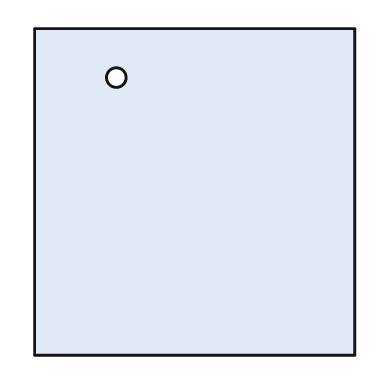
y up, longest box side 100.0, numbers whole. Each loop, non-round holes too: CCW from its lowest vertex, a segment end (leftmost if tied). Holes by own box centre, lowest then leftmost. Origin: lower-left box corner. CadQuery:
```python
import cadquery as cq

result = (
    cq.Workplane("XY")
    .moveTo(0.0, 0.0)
    .lineTo(98.0, 0.0)
    .lineTo(98.0, 100.0)
    .lineTo(0.0, 100.0)
    .close()
    .moveTo(25.0, 85.0)
    .circle(3.0)
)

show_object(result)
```